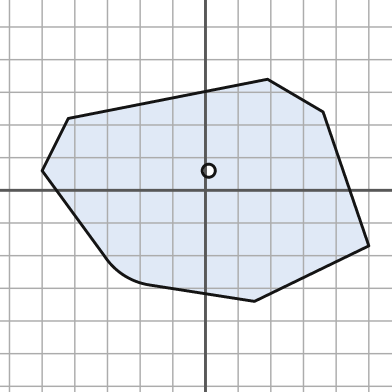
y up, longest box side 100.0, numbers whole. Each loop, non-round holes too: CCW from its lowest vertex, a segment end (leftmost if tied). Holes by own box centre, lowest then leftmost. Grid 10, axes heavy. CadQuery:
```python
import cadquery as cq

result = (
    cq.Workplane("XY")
    .moveTo(15.0, -34.0)
    .lineTo(50.0, -17.0)
    .lineTo(36.0, 24.0)
    .lineTo(19.0, 34.0)
    .lineTo(-42.0, 22.0)
    .lineTo(-50.0, 6.0)
    .lineTo(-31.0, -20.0)
    .threePointArc((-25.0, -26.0), (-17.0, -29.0))
    .close()
    .moveTo(1.0, 6.0)
    .circle(2.0)
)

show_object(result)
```